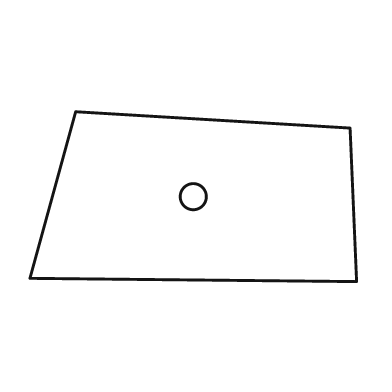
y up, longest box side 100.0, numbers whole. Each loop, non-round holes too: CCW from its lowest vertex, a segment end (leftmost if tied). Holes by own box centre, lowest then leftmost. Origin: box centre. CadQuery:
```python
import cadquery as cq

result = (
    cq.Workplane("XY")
    .moveTo(50.0, -26.0)
    .lineTo(48.0, 21.0)
    .lineTo(-36.0, 26.0)
    .lineTo(-50.0, -25.0)
    .close()
    .moveTo(0.0, 0.0)
    .circle(4.0)
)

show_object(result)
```